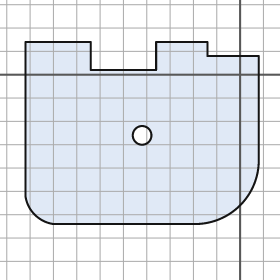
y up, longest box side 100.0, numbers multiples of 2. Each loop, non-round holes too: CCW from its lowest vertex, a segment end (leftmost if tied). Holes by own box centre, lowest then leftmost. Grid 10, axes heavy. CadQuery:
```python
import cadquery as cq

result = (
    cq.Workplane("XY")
    .moveTo(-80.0, -64.0)
    .lineTo(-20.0, -64.0)
    .threePointArc((0.0, -56.0), (8.0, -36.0))
    .lineTo(8.0, 8.0)
    .lineTo(-14.0, 8.0)
    .lineTo(-14.0, 14.0)
    .lineTo(-36.0, 14.0)
    .lineTo(-36.0, 2.0)
    .lineTo(-64.0, 2.0)
    .lineTo(-64.0, 14.0)
    .lineTo(-92.0, 14.0)
    .lineTo(-92.0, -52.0)
    .threePointArc((-88.0, -60.0), (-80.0, -64.0))
    .close()
    .moveTo(-42.0, -26.0)
    .circle(4.0)
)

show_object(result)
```